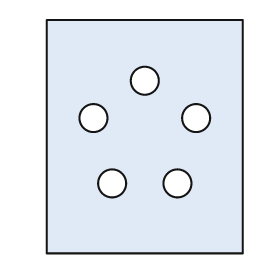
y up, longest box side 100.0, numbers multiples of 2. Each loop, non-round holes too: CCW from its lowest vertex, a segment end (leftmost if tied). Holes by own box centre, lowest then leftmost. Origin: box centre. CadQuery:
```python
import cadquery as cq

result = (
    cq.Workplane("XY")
    .moveTo(-42.0, -50.0)
    .lineTo(42.0, -50.0)
    .lineTo(42.0, 50.0)
    .lineTo(-42.0, 50.0)
    .close()
    .moveTo(-14.0, -20.0)
    .circle(6.0)
    .moveTo(14.0, -20.0)
    .circle(6.0)
    .moveTo(-22.0, 8.0)
    .circle(6.0)
    .moveTo(22.0, 8.0)
    .circle(6.0)
    .moveTo(0.0, 24.0)
    .circle(6.0)
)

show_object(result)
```